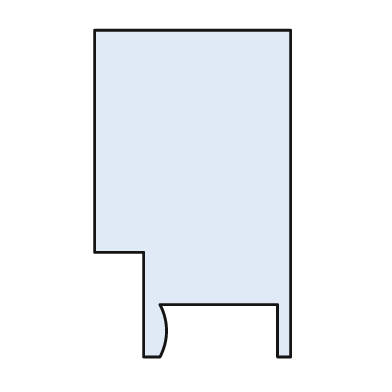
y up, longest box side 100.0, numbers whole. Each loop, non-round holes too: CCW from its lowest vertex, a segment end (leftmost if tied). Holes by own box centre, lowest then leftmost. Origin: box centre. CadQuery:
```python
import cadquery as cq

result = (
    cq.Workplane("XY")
    .moveTo(-15.0, -50.0)
    .lineTo(-10.0, -50.0)
    .threePointArc((-8.0, -42.0), (-10.0, -34.0))
    .lineTo(26.0, -34.0)
    .lineTo(26.0, -50.0)
    .lineTo(30.0, -50.0)
    .lineTo(30.0, 50.0)
    .lineTo(-30.0, 50.0)
    .lineTo(-30.0, -18.0)
    .lineTo(-15.0, -18.0)
    .close()
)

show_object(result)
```